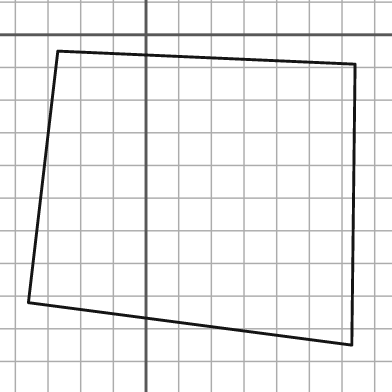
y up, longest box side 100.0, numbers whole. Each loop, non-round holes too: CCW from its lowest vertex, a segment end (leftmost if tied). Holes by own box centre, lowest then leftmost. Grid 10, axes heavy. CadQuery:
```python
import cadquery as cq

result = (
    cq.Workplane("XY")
    .moveTo(63.0, -95.0)
    .lineTo(64.0, -9.0)
    .lineTo(-27.0, -5.0)
    .lineTo(-36.0, -82.0)
    .close()
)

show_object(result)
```